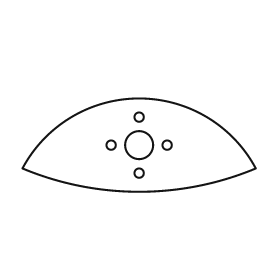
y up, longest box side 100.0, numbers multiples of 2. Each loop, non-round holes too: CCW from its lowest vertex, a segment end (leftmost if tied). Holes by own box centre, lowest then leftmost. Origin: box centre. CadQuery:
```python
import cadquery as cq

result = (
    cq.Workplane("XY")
    .moveTo(-50.0, -10.0)
    .threePointArc((0.0, -20.0), (50.0, -10.0))
    .threePointArc((0.0, 20.0), (-50.0, -10.0))
    .close()
    .moveTo(0.0, -12.0)
    .circle(2.0)
    .moveTo(-12.0, 0.0)
    .circle(2.0)
    .moveTo(0.0, 0.0)
    .circle(6.0)
    .moveTo(12.0, 0.0)
    .circle(2.0)
    .moveTo(0.0, 12.0)
    .circle(2.0)
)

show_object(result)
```